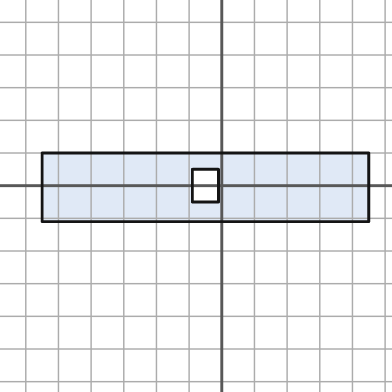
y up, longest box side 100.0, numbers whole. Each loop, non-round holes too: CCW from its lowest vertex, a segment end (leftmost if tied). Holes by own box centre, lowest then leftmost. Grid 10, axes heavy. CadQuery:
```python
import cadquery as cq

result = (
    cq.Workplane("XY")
    .moveTo(-55.0, -11.0)
    .lineTo(45.0, -11.0)
    .lineTo(45.0, 10.0)
    .lineTo(-55.0, 10.0)
    .close()
    .moveTo(-9.0, -5.0)
    .lineTo(-1.0, -5.0)
    .lineTo(-1.0, 5.0)
    .lineTo(-9.0, 5.0)
    .close()
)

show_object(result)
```